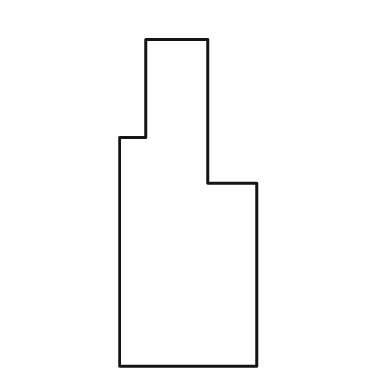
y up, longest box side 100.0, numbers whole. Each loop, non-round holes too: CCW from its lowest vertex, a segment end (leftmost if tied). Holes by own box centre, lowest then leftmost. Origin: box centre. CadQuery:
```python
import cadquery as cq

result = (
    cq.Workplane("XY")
    .moveTo(-21.0, -50.0)
    .lineTo(21.0, -50.0)
    .lineTo(21.0, 6.0)
    .lineTo(6.0, 6.0)
    .lineTo(6.0, 50.0)
    .lineTo(-13.0, 50.0)
    .lineTo(-13.0, 20.0)
    .lineTo(-21.0, 20.0)
    .close()
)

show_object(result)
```